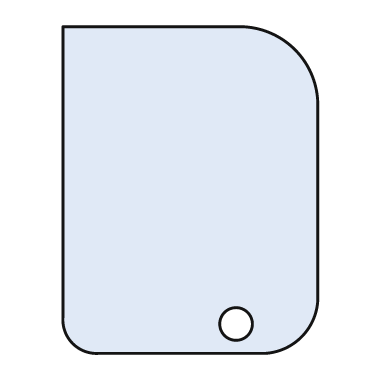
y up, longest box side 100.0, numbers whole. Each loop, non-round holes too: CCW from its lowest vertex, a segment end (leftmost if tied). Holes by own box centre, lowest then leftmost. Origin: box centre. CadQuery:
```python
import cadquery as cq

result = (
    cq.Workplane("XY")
    .moveTo(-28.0, -50.0)
    .lineTo(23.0, -50.0)
    .threePointArc((34.0, -45.0), (39.0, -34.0))
    .lineTo(39.0, 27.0)
    .threePointArc((32.0, 43.0), (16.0, 50.0))
    .lineTo(-39.0, 50.0)
    .lineTo(-39.0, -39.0)
    .threePointArc((-36.0, -47.0), (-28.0, -50.0))
    .close()
    .moveTo(14.0, -41.0)
    .circle(5.0)
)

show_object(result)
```